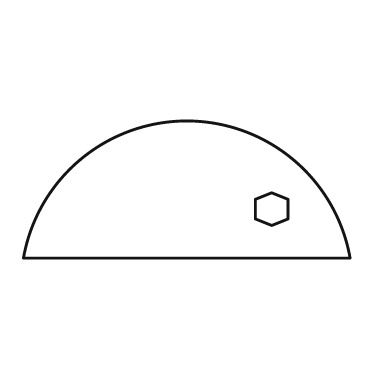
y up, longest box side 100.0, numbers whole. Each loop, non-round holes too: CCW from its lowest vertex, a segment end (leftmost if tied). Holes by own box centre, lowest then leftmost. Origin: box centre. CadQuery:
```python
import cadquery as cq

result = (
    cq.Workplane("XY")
    .moveTo(-50.0, -21.0)
    .lineTo(50.0, -21.0)
    .threePointArc((0.0, 21.0), (-50.0, -21.0))
    .close()
    .moveTo(26.0, -11.0)
    .lineTo(31.0, -9.0)
    .lineTo(31.0, -3.0)
    .lineTo(26.0, -1.0)
    .lineTo(21.0, -3.0)
    .lineTo(21.0, -9.0)
    .close()
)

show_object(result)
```